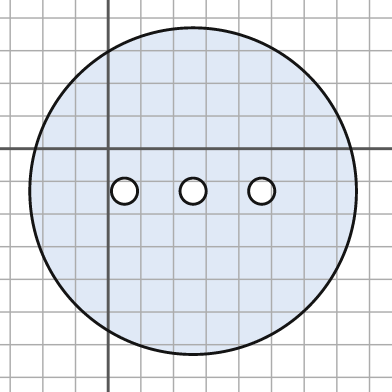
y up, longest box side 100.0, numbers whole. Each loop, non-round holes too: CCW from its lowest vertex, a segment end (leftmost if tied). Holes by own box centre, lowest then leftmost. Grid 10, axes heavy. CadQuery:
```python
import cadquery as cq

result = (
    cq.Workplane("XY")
    .moveTo(26.0, -13.0)
    .circle(50.0)
    .moveTo(5.0, -13.0)
    .circle(4.0)
    .moveTo(26.0, -13.0)
    .circle(4.0)
    .moveTo(47.0, -13.0)
    .circle(4.0)
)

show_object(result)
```